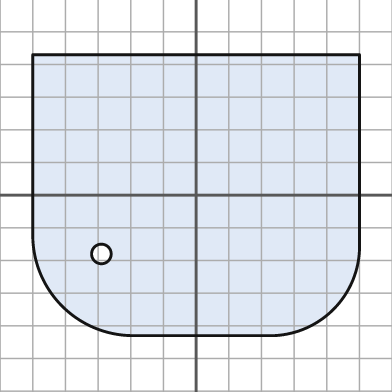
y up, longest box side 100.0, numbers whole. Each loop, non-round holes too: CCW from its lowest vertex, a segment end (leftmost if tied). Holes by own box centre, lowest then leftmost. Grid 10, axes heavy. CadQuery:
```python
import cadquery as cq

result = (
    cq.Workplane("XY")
    .moveTo(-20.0, -43.0)
    .lineTo(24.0, -43.0)
    .threePointArc((42.0, -35.0), (50.0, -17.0))
    .lineTo(50.0, 43.0)
    .lineTo(-50.0, 43.0)
    .lineTo(-50.0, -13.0)
    .threePointArc((-41.0, -34.0), (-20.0, -43.0))
    .close()
    .moveTo(-29.0, -18.0)
    .circle(3.0)
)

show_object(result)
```